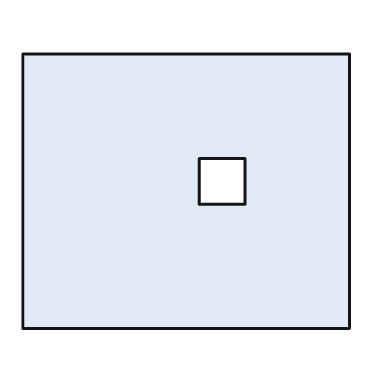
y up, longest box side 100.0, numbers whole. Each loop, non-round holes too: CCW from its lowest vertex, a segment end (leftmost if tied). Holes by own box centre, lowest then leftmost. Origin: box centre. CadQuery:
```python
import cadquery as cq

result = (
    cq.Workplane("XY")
    .moveTo(-50.0, -42.0)
    .lineTo(50.0, -42.0)
    .lineTo(50.0, 42.0)
    .lineTo(-50.0, 42.0)
    .close()
    .moveTo(4.0, -4.0)
    .lineTo(18.0, -4.0)
    .lineTo(18.0, 10.0)
    .lineTo(4.0, 10.0)
    .close()
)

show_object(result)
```